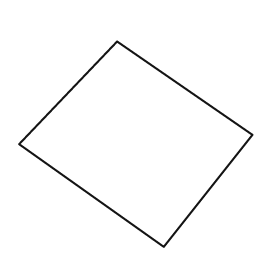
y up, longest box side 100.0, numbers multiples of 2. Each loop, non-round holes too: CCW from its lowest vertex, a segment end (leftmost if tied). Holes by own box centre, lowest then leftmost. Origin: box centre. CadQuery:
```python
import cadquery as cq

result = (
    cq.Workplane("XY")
    .moveTo(12.0, -44.0)
    .lineTo(50.0, 4.0)
    .lineTo(-8.0, 44.0)
    .lineTo(-50.0, 0.0)
    .close()
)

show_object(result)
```